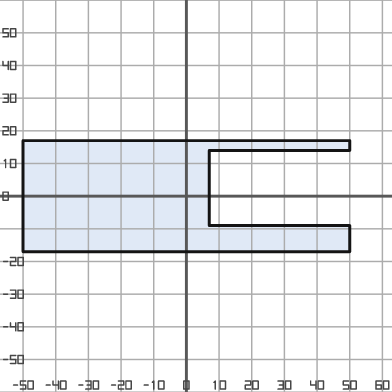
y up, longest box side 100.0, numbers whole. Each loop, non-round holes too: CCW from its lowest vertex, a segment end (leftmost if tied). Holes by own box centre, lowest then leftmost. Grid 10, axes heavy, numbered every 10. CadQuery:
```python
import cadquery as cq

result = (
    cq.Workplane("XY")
    .moveTo(-50.0, -17.0)
    .lineTo(50.0, -17.0)
    .lineTo(50.0, -9.0)
    .lineTo(7.0, -9.0)
    .lineTo(7.0, 14.0)
    .lineTo(50.0, 14.0)
    .lineTo(50.0, 17.0)
    .lineTo(-50.0, 17.0)
    .close()
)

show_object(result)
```